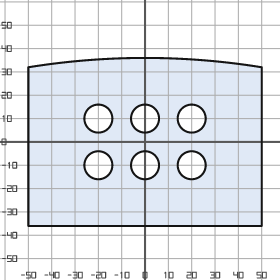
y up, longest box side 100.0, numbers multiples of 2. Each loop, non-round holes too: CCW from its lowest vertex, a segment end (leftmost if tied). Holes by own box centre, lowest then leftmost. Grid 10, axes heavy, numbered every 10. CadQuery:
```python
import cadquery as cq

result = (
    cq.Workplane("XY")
    .moveTo(-50.0, -36.0)
    .lineTo(50.0, -36.0)
    .lineTo(50.0, 32.0)
    .threePointArc((0.0, 36.0), (-50.0, 32.0))
    .close()
    .moveTo(-20.0, -10.0)
    .circle(6.0)
    .moveTo(0.0, -10.0)
    .circle(6.0)
    .moveTo(20.0, -10.0)
    .circle(6.0)
    .moveTo(-20.0, 10.0)
    .circle(6.0)
    .moveTo(0.0, 10.0)
    .circle(6.0)
    .moveTo(20.0, 10.0)
    .circle(6.0)
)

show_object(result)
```